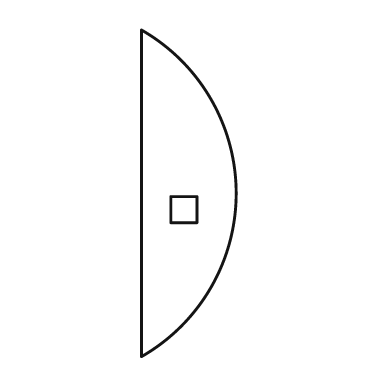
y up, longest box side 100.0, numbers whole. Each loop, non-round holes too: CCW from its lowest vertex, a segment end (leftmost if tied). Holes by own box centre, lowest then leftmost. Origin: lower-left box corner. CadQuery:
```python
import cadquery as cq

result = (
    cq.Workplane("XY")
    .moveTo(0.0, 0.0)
    .threePointArc((29.0, 50.0), (0.0, 100.0))
    .close()
    .moveTo(9.0, 41.0)
    .lineTo(17.0, 41.0)
    .lineTo(17.0, 49.0)
    .lineTo(9.0, 49.0)
    .close()
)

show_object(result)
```